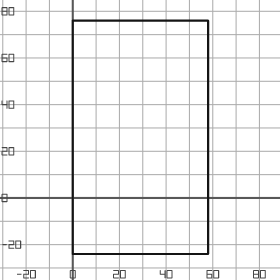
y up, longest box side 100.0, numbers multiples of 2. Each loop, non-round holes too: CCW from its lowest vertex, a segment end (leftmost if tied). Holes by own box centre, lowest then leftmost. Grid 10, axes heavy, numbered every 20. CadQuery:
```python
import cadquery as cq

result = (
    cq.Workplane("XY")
    .moveTo(0.0, -24.0)
    .lineTo(58.0, -24.0)
    .lineTo(58.0, 76.0)
    .lineTo(0.0, 76.0)
    .close()
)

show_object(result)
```